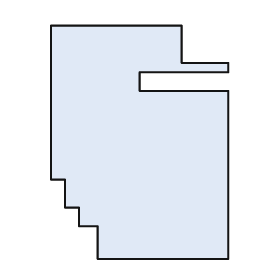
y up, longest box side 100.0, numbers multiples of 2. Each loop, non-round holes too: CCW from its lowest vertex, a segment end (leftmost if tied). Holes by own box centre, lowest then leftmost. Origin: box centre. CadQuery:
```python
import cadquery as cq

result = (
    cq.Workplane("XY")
    .moveTo(-18.0, -50.0)
    .lineTo(38.0, -50.0)
    .lineTo(38.0, 22.0)
    .lineTo(0.0, 22.0)
    .lineTo(0.0, 30.0)
    .lineTo(38.0, 30.0)
    .lineTo(38.0, 34.0)
    .lineTo(18.0, 34.0)
    .lineTo(18.0, 50.0)
    .lineTo(-38.0, 50.0)
    .lineTo(-38.0, -16.0)
    .lineTo(-32.0, -16.0)
    .lineTo(-32.0, -28.0)
    .lineTo(-26.0, -28.0)
    .lineTo(-26.0, -36.0)
    .lineTo(-18.0, -36.0)
    .close()
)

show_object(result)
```